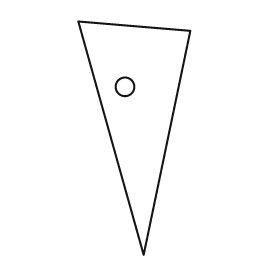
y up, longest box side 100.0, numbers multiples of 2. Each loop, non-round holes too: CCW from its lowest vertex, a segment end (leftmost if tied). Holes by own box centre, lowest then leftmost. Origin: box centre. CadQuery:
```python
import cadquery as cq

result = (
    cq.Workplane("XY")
    .moveTo(4.0, -50.0)
    .lineTo(24.0, 46.0)
    .lineTo(-24.0, 50.0)
    .close()
    .moveTo(-4.0, 22.0)
    .circle(4.0)
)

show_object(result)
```